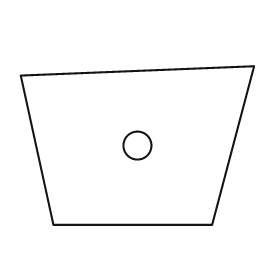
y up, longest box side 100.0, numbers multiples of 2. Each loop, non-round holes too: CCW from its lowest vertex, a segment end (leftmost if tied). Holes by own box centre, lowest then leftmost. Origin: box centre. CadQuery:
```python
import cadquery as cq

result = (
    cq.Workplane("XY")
    .moveTo(-36.0, -34.0)
    .lineTo(32.0, -34.0)
    .lineTo(50.0, 34.0)
    .lineTo(-50.0, 30.0)
    .close()
    .moveTo(0.0, 0.0)
    .circle(6.0)
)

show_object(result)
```